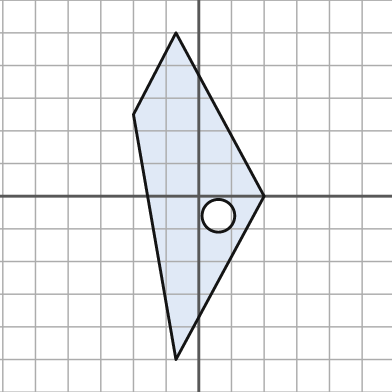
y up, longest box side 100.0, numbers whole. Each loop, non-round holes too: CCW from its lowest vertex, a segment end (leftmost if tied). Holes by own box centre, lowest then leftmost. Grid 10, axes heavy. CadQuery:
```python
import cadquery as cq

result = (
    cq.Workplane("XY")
    .moveTo(-7.0, -50.0)
    .lineTo(20.0, 0.0)
    .lineTo(-7.0, 50.0)
    .lineTo(-20.0, 25.0)
    .close()
    .moveTo(6.0, -6.0)
    .circle(5.0)
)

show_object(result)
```